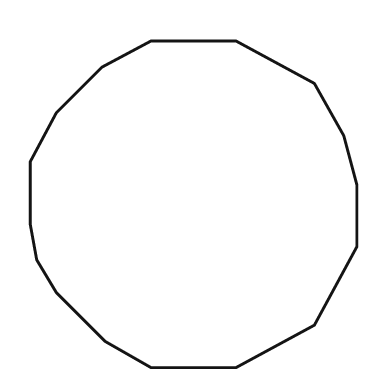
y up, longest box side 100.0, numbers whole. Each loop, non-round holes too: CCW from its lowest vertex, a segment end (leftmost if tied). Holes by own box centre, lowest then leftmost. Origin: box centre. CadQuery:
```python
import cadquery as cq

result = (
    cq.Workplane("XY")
    .moveTo(-13.0, -50.0)
    .lineTo(13.0, -50.0)
    .lineTo(37.0, -37.0)
    .lineTo(50.0, -13.0)
    .lineTo(50.0, 6.0)
    .lineTo(46.0, 21.0)
    .lineTo(37.0, 37.0)
    .lineTo(13.0, 50.0)
    .lineTo(-13.0, 50.0)
    .lineTo(-28.0, 42.0)
    .lineTo(-42.0, 28.0)
    .lineTo(-50.0, 13.0)
    .lineTo(-50.0, -6.0)
    .lineTo(-48.0, -17.0)
    .lineTo(-42.0, -27.0)
    .lineTo(-27.0, -42.0)
    .close()
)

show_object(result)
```